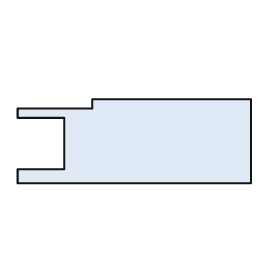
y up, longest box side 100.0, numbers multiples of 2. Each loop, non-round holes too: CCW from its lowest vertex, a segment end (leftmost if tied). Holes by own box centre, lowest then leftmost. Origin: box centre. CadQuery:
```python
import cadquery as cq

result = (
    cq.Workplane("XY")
    .moveTo(-50.0, -18.0)
    .lineTo(50.0, -18.0)
    .lineTo(50.0, 18.0)
    .lineTo(-18.0, 18.0)
    .lineTo(-18.0, 14.0)
    .lineTo(-50.0, 14.0)
    .lineTo(-50.0, 10.0)
    .lineTo(-30.0, 10.0)
    .lineTo(-30.0, -12.0)
    .lineTo(-50.0, -12.0)
    .close()
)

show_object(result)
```